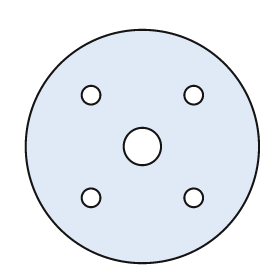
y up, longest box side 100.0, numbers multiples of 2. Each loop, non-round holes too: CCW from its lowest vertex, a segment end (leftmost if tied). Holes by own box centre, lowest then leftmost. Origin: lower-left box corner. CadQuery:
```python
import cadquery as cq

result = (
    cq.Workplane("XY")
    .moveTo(50.0, 50.0)
    .circle(50.0)
    .moveTo(28.0, 28.0)
    .circle(4.0)
    .moveTo(72.0, 28.0)
    .circle(4.0)
    .moveTo(50.0, 50.0)
    .circle(8.0)
    .moveTo(28.0, 72.0)
    .circle(4.0)
    .moveTo(72.0, 72.0)
    .circle(4.0)
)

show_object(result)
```